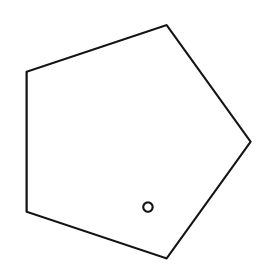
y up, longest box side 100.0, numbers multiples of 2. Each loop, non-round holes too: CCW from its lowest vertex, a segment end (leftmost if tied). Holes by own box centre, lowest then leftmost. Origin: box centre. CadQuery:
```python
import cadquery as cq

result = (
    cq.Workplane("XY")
    .moveTo(12.0, -50.0)
    .lineTo(48.0, 0.0)
    .lineTo(12.0, 50.0)
    .lineTo(-48.0, 30.0)
    .lineTo(-48.0, -30.0)
    .close()
    .moveTo(4.0, -28.0)
    .circle(2.0)
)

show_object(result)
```